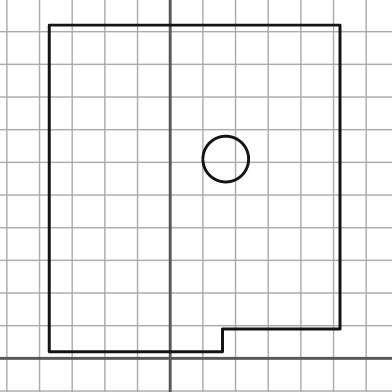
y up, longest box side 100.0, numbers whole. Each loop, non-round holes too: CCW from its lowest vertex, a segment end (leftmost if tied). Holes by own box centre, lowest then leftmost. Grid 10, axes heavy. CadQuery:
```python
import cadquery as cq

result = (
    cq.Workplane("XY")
    .moveTo(-37.0, 2.0)
    .lineTo(16.0, 2.0)
    .lineTo(16.0, 9.0)
    .lineTo(52.0, 9.0)
    .lineTo(52.0, 102.0)
    .lineTo(-37.0, 102.0)
    .close()
    .moveTo(17.0, 61.0)
    .circle(7.0)
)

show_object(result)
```